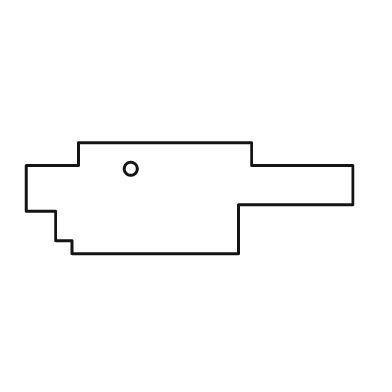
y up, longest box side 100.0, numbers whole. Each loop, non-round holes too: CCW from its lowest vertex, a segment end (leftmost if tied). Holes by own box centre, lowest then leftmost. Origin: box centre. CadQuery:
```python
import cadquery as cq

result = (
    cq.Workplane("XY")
    .moveTo(-36.0, -17.0)
    .lineTo(15.0, -17.0)
    .lineTo(15.0, -2.0)
    .lineTo(50.0, -2.0)
    .lineTo(50.0, 10.0)
    .lineTo(19.0, 10.0)
    .lineTo(19.0, 17.0)
    .lineTo(-34.0, 17.0)
    .lineTo(-34.0, 10.0)
    .lineTo(-50.0, 10.0)
    .lineTo(-50.0, -4.0)
    .lineTo(-41.0, -4.0)
    .lineTo(-41.0, -13.0)
    .lineTo(-36.0, -13.0)
    .close()
    .moveTo(-18.0, 9.0)
    .circle(2.0)
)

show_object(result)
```